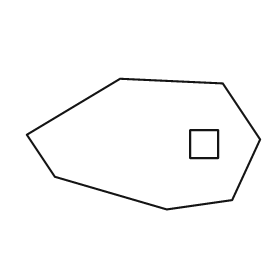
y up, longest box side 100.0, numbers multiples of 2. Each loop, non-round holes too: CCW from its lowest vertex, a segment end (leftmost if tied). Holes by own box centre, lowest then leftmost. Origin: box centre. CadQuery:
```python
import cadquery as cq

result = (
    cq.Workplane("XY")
    .moveTo(10.0, -28.0)
    .lineTo(38.0, -24.0)
    .lineTo(50.0, 2.0)
    .lineTo(34.0, 26.0)
    .lineTo(-10.0, 28.0)
    .lineTo(-50.0, 4.0)
    .lineTo(-38.0, -14.0)
    .close()
    .moveTo(20.0, -6.0)
    .lineTo(32.0, -6.0)
    .lineTo(32.0, 6.0)
    .lineTo(20.0, 6.0)
    .close()
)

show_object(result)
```